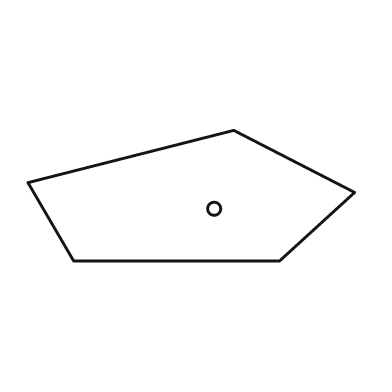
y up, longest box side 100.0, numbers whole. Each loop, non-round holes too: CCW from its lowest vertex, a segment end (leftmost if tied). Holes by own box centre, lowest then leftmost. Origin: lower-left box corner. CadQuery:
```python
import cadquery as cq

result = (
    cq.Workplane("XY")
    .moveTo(14.0, 0.0)
    .lineTo(77.0, 0.0)
    .lineTo(100.0, 21.0)
    .lineTo(63.0, 40.0)
    .lineTo(0.0, 24.0)
    .close()
    .moveTo(57.0, 16.0)
    .circle(2.0)
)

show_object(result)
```